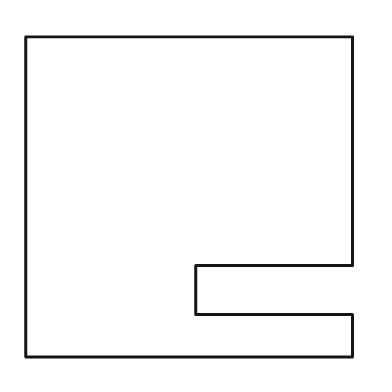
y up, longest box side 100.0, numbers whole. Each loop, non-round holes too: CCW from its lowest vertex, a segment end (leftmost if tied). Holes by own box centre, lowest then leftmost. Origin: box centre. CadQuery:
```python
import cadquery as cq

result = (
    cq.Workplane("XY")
    .moveTo(-50.0, -49.0)
    .lineTo(50.0, -49.0)
    .lineTo(50.0, -36.0)
    .lineTo(2.0, -36.0)
    .lineTo(2.0, -21.0)
    .lineTo(50.0, -21.0)
    .lineTo(50.0, 49.0)
    .lineTo(-50.0, 49.0)
    .close()
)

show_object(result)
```